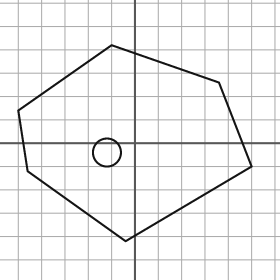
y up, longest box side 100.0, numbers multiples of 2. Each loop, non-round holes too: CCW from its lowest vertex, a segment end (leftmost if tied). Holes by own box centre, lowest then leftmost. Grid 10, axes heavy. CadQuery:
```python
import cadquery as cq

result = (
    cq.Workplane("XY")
    .moveTo(-4.0, -42.0)
    .lineTo(50.0, -10.0)
    .lineTo(36.0, 26.0)
    .lineTo(-10.0, 42.0)
    .lineTo(-50.0, 14.0)
    .lineTo(-46.0, -12.0)
    .close()
    .moveTo(-12.0, -4.0)
    .circle(6.0)
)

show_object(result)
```